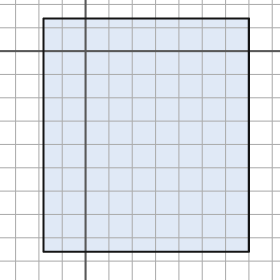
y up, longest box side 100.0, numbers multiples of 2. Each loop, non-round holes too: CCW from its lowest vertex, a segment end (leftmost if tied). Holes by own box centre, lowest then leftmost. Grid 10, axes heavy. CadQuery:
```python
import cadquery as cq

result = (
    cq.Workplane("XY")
    .moveTo(-18.0, -86.0)
    .lineTo(70.0, -86.0)
    .lineTo(70.0, 14.0)
    .lineTo(-18.0, 14.0)
    .close()
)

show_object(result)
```